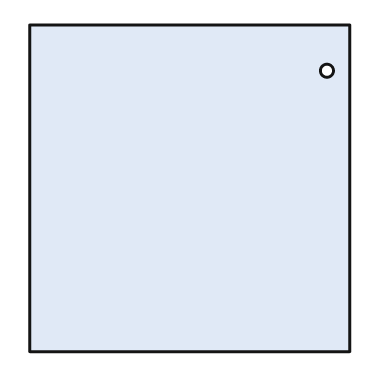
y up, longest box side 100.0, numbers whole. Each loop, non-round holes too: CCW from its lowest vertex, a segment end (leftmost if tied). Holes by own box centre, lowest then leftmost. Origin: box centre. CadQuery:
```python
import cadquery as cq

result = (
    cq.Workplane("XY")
    .moveTo(-49.0, -50.0)
    .lineTo(49.0, -50.0)
    .lineTo(49.0, 50.0)
    .lineTo(-49.0, 50.0)
    .close()
    .moveTo(42.0, 36.0)
    .circle(2.0)
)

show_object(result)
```